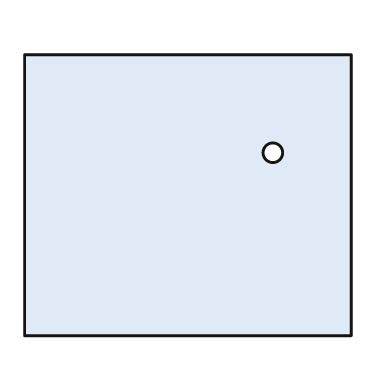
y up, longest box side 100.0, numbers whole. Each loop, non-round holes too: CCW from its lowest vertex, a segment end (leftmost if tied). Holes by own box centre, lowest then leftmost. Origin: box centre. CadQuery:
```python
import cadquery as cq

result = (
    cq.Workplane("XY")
    .moveTo(-50.0, -43.0)
    .lineTo(50.0, -43.0)
    .lineTo(50.0, 43.0)
    .lineTo(-50.0, 43.0)
    .close()
    .moveTo(26.0, 13.0)
    .circle(3.0)
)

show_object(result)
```